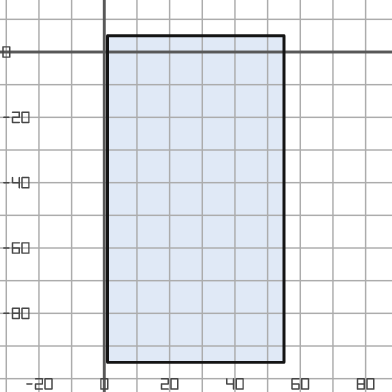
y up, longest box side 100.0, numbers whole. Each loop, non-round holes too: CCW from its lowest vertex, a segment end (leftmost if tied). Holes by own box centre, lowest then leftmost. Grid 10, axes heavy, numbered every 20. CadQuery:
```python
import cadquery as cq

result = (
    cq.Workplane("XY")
    .moveTo(1.0, -95.0)
    .lineTo(55.0, -95.0)
    .lineTo(55.0, 5.0)
    .lineTo(1.0, 5.0)
    .close()
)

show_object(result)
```